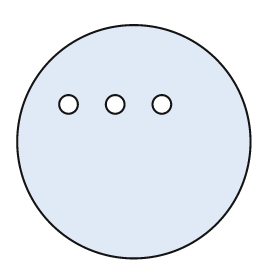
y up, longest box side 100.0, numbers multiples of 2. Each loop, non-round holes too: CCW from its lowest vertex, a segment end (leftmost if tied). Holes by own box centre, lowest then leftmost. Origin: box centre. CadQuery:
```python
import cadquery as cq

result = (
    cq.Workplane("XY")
    .moveTo(0.0, 0.0)
    .circle(50.0)
    .moveTo(-28.0, 16.0)
    .circle(4.0)
    .moveTo(-8.0, 16.0)
    .circle(4.0)
    .moveTo(12.0, 16.0)
    .circle(4.0)
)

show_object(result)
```